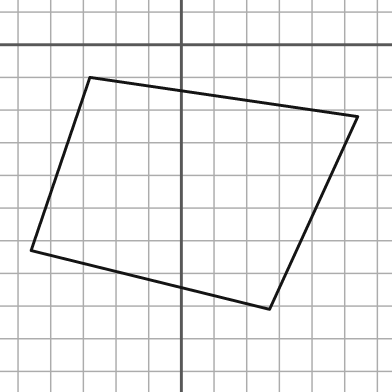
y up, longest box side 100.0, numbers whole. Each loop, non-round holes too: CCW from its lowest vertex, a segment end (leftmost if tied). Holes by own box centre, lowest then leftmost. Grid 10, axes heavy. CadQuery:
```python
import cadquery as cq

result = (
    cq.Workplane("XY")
    .moveTo(27.0, -81.0)
    .lineTo(54.0, -22.0)
    .lineTo(-28.0, -10.0)
    .lineTo(-46.0, -63.0)
    .close()
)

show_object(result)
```